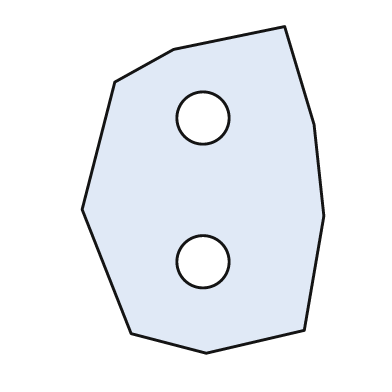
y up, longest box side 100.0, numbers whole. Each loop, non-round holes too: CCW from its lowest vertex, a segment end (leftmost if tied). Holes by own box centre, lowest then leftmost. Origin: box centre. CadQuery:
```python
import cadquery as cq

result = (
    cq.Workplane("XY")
    .moveTo(1.0, -50.0)
    .lineTo(31.0, -43.0)
    .lineTo(37.0, -8.0)
    .lineTo(34.0, 20.0)
    .lineTo(25.0, 50.0)
    .lineTo(-9.0, 43.0)
    .lineTo(-27.0, 33.0)
    .lineTo(-37.0, -6.0)
    .lineTo(-22.0, -44.0)
    .close()
    .moveTo(0.0, -22.0)
    .circle(8.0)
    .moveTo(0.0, 22.0)
    .circle(8.0)
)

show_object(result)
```